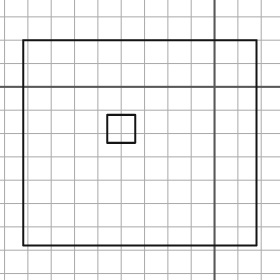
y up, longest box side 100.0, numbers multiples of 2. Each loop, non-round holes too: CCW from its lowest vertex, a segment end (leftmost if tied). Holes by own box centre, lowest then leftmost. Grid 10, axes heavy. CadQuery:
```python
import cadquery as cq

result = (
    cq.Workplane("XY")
    .moveTo(-82.0, -68.0)
    .lineTo(18.0, -68.0)
    .lineTo(18.0, 20.0)
    .lineTo(-82.0, 20.0)
    .close()
    .moveTo(-46.0, -24.0)
    .lineTo(-34.0, -24.0)
    .lineTo(-34.0, -12.0)
    .lineTo(-46.0, -12.0)
    .close()
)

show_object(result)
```